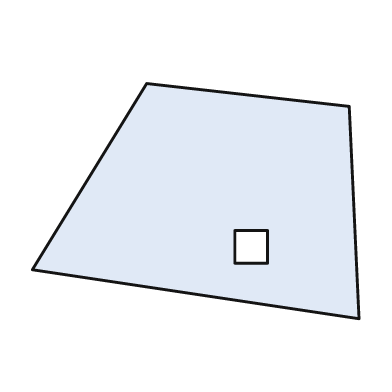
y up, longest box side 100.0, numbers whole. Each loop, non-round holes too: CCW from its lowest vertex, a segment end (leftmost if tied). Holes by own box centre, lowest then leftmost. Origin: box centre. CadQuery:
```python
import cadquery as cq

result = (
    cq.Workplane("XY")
    .moveTo(50.0, -36.0)
    .lineTo(47.0, 29.0)
    .lineTo(-15.0, 36.0)
    .lineTo(-50.0, -21.0)
    .close()
    .moveTo(12.0, -19.0)
    .lineTo(22.0, -19.0)
    .lineTo(22.0, -9.0)
    .lineTo(12.0, -9.0)
    .close()
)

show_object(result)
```